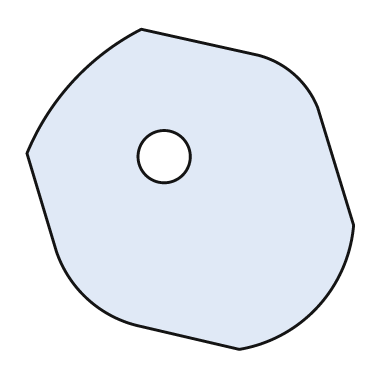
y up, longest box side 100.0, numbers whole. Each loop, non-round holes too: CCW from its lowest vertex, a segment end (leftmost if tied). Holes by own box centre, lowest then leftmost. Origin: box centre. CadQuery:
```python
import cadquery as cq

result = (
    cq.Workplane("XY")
    .moveTo(15.0, -49.0)
    .threePointArc((39.0, -36.0), (50.0, -11.0))
    .lineTo(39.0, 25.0)
    .threePointArc((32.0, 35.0), (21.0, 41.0))
    .lineTo(-15.0, 49.0)
    .threePointArc((-36.0, 33.0), (-50.0, 11.0))
    .lineTo(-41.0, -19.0)
    .threePointArc((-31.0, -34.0), (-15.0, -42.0))
    .close()
    .moveTo(-8.0, 10.0)
    .circle(8.0)
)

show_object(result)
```